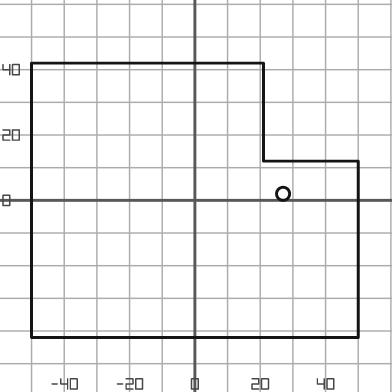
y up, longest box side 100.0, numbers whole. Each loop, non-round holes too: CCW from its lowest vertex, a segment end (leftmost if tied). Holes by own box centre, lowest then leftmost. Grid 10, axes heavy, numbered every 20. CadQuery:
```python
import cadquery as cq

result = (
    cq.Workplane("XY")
    .moveTo(-50.0, -42.0)
    .lineTo(50.0, -42.0)
    .lineTo(50.0, 12.0)
    .lineTo(21.0, 12.0)
    .lineTo(21.0, 42.0)
    .lineTo(-50.0, 42.0)
    .close()
    .moveTo(27.0, 2.0)
    .circle(2.0)
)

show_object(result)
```